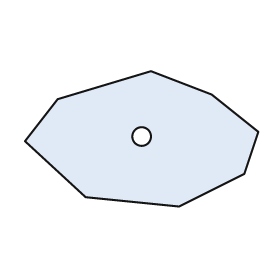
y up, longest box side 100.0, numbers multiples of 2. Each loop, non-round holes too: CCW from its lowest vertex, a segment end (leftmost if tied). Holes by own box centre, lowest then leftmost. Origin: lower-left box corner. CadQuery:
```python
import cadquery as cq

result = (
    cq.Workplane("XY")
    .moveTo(66.0, 0.0)
    .lineTo(94.0, 14.0)
    .lineTo(100.0, 32.0)
    .lineTo(80.0, 48.0)
    .lineTo(54.0, 58.0)
    .lineTo(14.0, 46.0)
    .lineTo(0.0, 28.0)
    .lineTo(26.0, 4.0)
    .close()
    .moveTo(50.0, 30.0)
    .circle(4.0)
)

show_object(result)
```